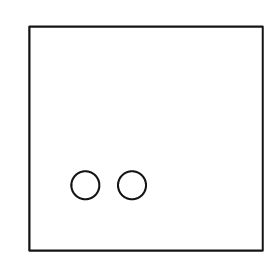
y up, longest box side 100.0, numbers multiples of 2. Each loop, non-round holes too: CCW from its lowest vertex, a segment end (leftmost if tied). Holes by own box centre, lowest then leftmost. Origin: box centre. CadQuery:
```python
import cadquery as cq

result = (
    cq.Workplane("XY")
    .moveTo(-50.0, -48.0)
    .lineTo(50.0, -48.0)
    .lineTo(50.0, 48.0)
    .lineTo(-50.0, 48.0)
    .close()
    .moveTo(-26.0, -20.0)
    .circle(6.0)
    .moveTo(-6.0, -20.0)
    .circle(6.0)
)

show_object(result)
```